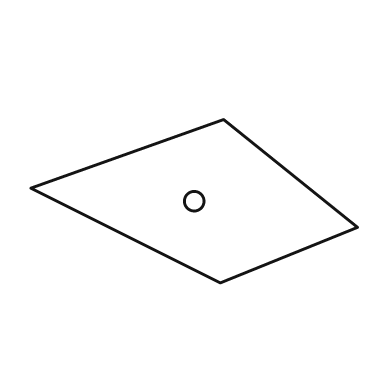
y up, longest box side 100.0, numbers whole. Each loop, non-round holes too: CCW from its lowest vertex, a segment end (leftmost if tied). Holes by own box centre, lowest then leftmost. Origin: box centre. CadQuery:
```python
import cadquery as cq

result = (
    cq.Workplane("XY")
    .moveTo(8.0, -25.0)
    .lineTo(50.0, -8.0)
    .lineTo(9.0, 25.0)
    .lineTo(-50.0, 4.0)
    .close()
    .moveTo(0.0, 0.0)
    .circle(3.0)
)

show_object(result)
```